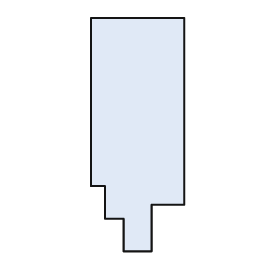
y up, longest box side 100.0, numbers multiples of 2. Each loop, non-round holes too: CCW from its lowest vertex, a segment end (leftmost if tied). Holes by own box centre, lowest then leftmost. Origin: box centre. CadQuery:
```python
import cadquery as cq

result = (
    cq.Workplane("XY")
    .moveTo(-6.0, -50.0)
    .lineTo(6.0, -50.0)
    .lineTo(6.0, -30.0)
    .lineTo(20.0, -30.0)
    .lineTo(20.0, 50.0)
    .lineTo(-20.0, 50.0)
    .lineTo(-20.0, -22.0)
    .lineTo(-14.0, -22.0)
    .lineTo(-14.0, -36.0)
    .lineTo(-6.0, -36.0)
    .close()
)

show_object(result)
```